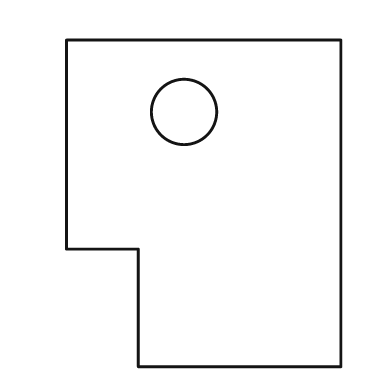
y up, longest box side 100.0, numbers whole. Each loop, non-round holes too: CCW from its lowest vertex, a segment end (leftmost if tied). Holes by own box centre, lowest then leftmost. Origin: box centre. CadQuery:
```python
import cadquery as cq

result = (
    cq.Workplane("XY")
    .moveTo(-20.0, -50.0)
    .lineTo(42.0, -50.0)
    .lineTo(42.0, 50.0)
    .lineTo(-42.0, 50.0)
    .lineTo(-42.0, -14.0)
    .lineTo(-20.0, -14.0)
    .close()
    .moveTo(-6.0, 28.0)
    .circle(10.0)
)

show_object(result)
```